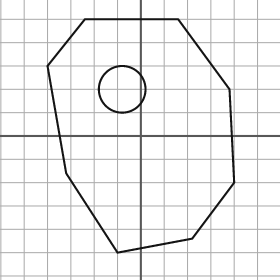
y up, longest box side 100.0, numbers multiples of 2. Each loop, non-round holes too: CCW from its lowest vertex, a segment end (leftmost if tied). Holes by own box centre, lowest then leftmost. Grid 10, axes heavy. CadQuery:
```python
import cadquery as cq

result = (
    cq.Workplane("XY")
    .moveTo(-10.0, -50.0)
    .lineTo(22.0, -44.0)
    .lineTo(40.0, -20.0)
    .lineTo(38.0, 20.0)
    .lineTo(16.0, 50.0)
    .lineTo(-24.0, 50.0)
    .lineTo(-40.0, 30.0)
    .lineTo(-32.0, -16.0)
    .close()
    .moveTo(-8.0, 20.0)
    .circle(10.0)
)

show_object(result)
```